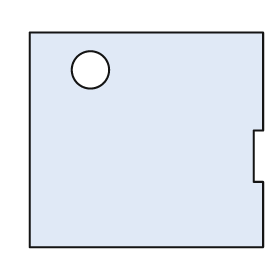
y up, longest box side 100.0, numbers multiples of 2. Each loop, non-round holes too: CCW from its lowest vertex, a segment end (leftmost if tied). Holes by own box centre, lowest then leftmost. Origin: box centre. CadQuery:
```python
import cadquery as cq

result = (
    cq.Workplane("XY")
    .moveTo(-50.0, -46.0)
    .lineTo(50.0, -46.0)
    .lineTo(50.0, -18.0)
    .lineTo(46.0, -18.0)
    .lineTo(46.0, 4.0)
    .lineTo(50.0, 4.0)
    .lineTo(50.0, 46.0)
    .lineTo(-50.0, 46.0)
    .close()
    .moveTo(-24.0, 30.0)
    .circle(8.0)
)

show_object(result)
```